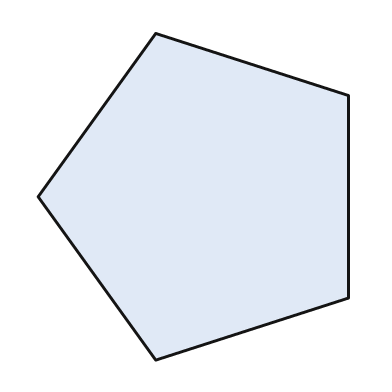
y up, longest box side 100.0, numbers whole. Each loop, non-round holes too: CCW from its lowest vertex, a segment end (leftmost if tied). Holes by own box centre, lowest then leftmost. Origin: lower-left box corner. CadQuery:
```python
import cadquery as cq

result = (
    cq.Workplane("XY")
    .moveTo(36.0, 0.0)
    .lineTo(95.0, 19.0)
    .lineTo(95.0, 81.0)
    .lineTo(36.0, 100.0)
    .lineTo(0.0, 50.0)
    .close()
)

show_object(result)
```